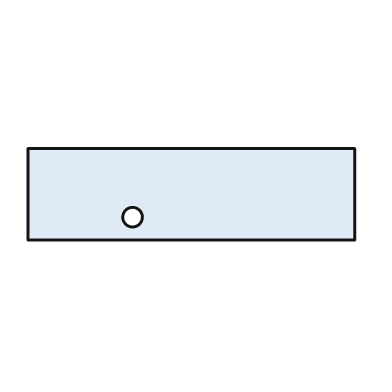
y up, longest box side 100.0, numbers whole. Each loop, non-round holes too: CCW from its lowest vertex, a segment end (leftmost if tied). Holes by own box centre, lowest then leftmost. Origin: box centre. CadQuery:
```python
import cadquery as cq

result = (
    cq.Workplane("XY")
    .moveTo(-50.0, -14.0)
    .lineTo(50.0, -14.0)
    .lineTo(50.0, 14.0)
    .lineTo(-50.0, 14.0)
    .close()
    .moveTo(-18.0, -7.0)
    .circle(3.0)
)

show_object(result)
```